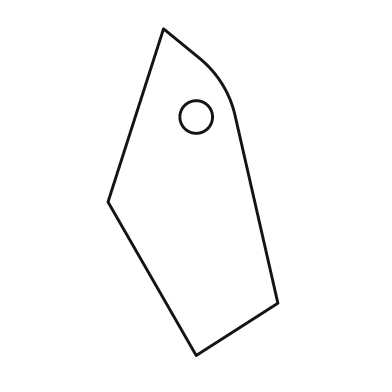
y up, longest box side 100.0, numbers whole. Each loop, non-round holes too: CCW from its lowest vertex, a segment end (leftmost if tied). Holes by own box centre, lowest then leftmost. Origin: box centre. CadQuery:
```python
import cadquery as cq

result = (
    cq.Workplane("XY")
    .moveTo(1.0, -50.0)
    .lineTo(26.0, -34.0)
    .lineTo(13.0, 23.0)
    .threePointArc((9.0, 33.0), (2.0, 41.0))
    .lineTo(-9.0, 50.0)
    .lineTo(-26.0, -3.0)
    .close()
    .moveTo(1.0, 23.0)
    .circle(5.0)
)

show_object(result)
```